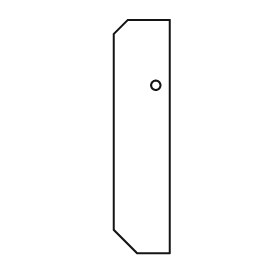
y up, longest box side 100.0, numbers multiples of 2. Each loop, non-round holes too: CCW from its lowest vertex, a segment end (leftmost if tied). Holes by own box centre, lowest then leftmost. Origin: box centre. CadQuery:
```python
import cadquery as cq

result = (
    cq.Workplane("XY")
    .moveTo(-2.0, -50.0)
    .lineTo(12.0, -50.0)
    .lineTo(12.0, 50.0)
    .lineTo(-6.0, 50.0)
    .lineTo(-12.0, 44.0)
    .lineTo(-12.0, -40.0)
    .close()
    .moveTo(6.0, 22.0)
    .circle(2.0)
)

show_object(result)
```